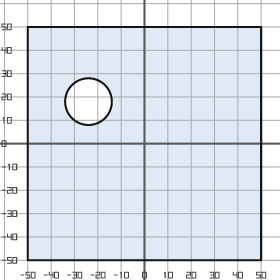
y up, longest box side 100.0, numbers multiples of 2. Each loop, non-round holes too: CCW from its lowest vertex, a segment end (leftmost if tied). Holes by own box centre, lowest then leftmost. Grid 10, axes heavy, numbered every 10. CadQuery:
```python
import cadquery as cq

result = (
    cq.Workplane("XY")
    .moveTo(-50.0, -50.0)
    .lineTo(50.0, -50.0)
    .lineTo(50.0, 50.0)
    .lineTo(-50.0, 50.0)
    .close()
    .moveTo(-24.0, 18.0)
    .circle(10.0)
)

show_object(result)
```